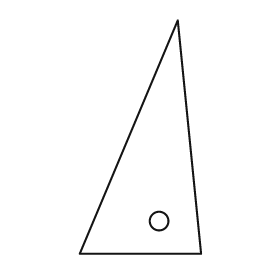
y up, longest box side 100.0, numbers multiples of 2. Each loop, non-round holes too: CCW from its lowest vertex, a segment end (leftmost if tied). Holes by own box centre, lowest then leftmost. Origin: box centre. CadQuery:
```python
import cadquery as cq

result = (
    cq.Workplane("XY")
    .moveTo(-26.0, -50.0)
    .lineTo(26.0, -50.0)
    .lineTo(16.0, 50.0)
    .close()
    .moveTo(8.0, -36.0)
    .circle(4.0)
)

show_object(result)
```